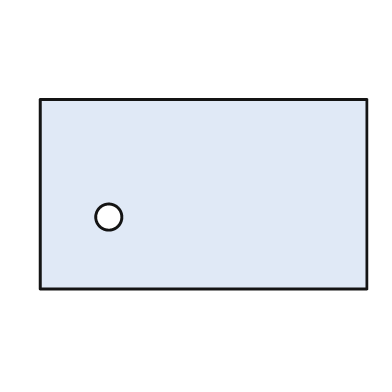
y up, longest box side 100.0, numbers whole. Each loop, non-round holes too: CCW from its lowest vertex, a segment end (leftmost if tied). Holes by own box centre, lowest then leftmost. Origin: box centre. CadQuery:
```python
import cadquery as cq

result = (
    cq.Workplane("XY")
    .moveTo(-50.0, -29.0)
    .lineTo(50.0, -29.0)
    .lineTo(50.0, 29.0)
    .lineTo(-50.0, 29.0)
    .close()
    .moveTo(-29.0, -7.0)
    .circle(4.0)
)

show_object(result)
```